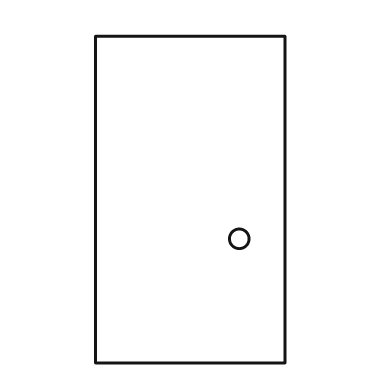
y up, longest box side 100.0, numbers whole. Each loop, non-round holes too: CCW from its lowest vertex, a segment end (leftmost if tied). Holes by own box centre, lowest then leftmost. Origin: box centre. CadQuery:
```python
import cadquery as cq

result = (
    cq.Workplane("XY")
    .moveTo(-29.0, -50.0)
    .lineTo(29.0, -50.0)
    .lineTo(29.0, 50.0)
    .lineTo(-29.0, 50.0)
    .close()
    .moveTo(15.0, -12.0)
    .circle(3.0)
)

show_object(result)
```